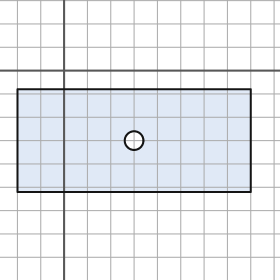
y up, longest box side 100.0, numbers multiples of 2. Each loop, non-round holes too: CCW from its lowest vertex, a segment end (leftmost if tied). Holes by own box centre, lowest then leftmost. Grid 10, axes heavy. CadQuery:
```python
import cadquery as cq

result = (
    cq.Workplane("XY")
    .moveTo(-20.0, -52.0)
    .lineTo(80.0, -52.0)
    .lineTo(80.0, -8.0)
    .lineTo(-20.0, -8.0)
    .close()
    .moveTo(30.0, -30.0)
    .circle(4.0)
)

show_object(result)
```